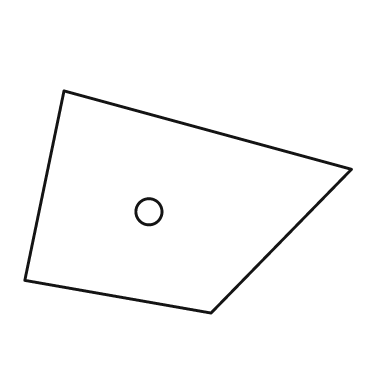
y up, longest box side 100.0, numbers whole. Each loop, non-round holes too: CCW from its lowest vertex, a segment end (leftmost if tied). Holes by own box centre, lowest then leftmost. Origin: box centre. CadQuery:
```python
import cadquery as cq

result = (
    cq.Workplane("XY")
    .moveTo(7.0, -34.0)
    .lineTo(50.0, 10.0)
    .lineTo(-38.0, 34.0)
    .lineTo(-50.0, -24.0)
    .close()
    .moveTo(-12.0, -3.0)
    .circle(4.0)
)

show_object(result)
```